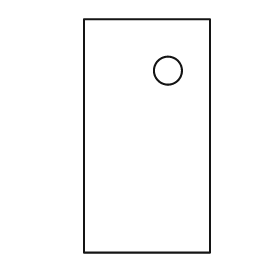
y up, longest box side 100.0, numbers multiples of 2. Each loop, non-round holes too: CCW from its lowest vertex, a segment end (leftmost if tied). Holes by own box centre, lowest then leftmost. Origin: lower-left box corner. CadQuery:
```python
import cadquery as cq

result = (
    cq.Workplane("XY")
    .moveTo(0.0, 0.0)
    .lineTo(54.0, 0.0)
    .lineTo(54.0, 100.0)
    .lineTo(0.0, 100.0)
    .close()
    .moveTo(36.0, 78.0)
    .circle(6.0)
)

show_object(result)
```